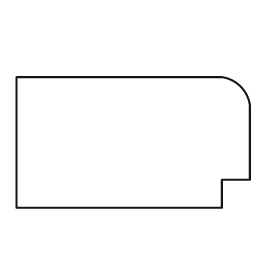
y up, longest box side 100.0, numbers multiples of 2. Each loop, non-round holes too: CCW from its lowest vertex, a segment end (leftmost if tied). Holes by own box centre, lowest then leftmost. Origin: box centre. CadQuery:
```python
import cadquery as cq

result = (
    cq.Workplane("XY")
    .moveTo(-50.0, -28.0)
    .lineTo(38.0, -28.0)
    .lineTo(38.0, -16.0)
    .lineTo(50.0, -16.0)
    .lineTo(50.0, 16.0)
    .threePointArc((46.0, 24.0), (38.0, 28.0))
    .lineTo(-50.0, 28.0)
    .close()
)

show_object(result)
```